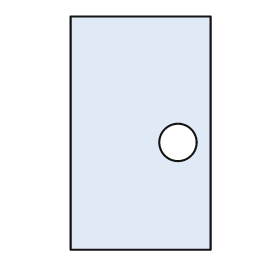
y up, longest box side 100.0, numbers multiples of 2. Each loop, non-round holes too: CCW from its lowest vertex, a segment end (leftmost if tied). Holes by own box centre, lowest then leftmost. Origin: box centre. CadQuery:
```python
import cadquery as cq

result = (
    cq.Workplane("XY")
    .moveTo(-30.0, -50.0)
    .lineTo(30.0, -50.0)
    .lineTo(30.0, 50.0)
    .lineTo(-30.0, 50.0)
    .close()
    .moveTo(16.0, -4.0)
    .circle(8.0)
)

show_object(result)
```